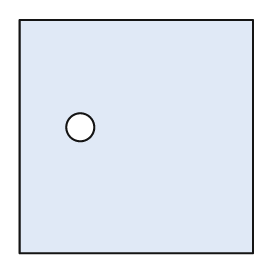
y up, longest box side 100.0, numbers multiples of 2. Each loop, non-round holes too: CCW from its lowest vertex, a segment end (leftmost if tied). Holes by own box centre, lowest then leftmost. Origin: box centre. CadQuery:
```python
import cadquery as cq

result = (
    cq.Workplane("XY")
    .moveTo(-50.0, -50.0)
    .lineTo(50.0, -50.0)
    .lineTo(50.0, 50.0)
    .lineTo(-50.0, 50.0)
    .close()
    .moveTo(-24.0, 4.0)
    .circle(6.0)
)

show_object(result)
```